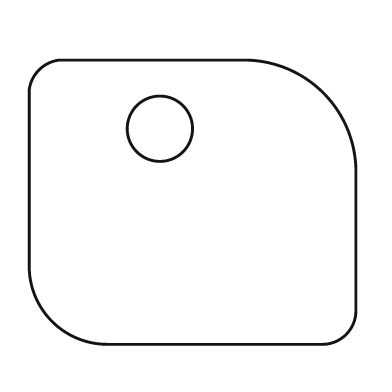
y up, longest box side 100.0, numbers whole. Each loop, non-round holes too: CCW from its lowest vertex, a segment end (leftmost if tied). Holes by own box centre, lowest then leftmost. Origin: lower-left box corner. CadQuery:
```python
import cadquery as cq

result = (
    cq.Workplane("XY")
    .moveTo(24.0, 0.0)
    .lineTo(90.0, 0.0)
    .threePointArc((97.0, 3.0), (100.0, 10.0))
    .lineTo(100.0, 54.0)
    .threePointArc((90.0, 77.0), (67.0, 87.0))
    .lineTo(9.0, 87.0)
    .threePointArc((3.0, 84.0), (0.0, 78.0))
    .lineTo(0.0, 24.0)
    .threePointArc((7.0, 7.0), (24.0, 0.0))
    .close()
    .moveTo(40.0, 66.0)
    .circle(10.0)
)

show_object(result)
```